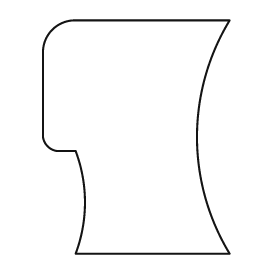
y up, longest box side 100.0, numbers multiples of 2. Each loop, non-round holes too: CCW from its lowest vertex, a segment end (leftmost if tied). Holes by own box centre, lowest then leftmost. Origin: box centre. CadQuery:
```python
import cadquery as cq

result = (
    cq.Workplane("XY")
    .moveTo(-26.0, -50.0)
    .lineTo(40.0, -50.0)
    .threePointArc((26.0, 0.0), (40.0, 50.0))
    .lineTo(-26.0, 50.0)
    .threePointArc((-36.0, 46.0), (-40.0, 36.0))
    .lineTo(-40.0, 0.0)
    .threePointArc((-38.0, -4.0), (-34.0, -6.0))
    .lineTo(-26.0, -6.0)
    .threePointArc((-22.0, -28.0), (-26.0, -50.0))
    .close()
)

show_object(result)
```